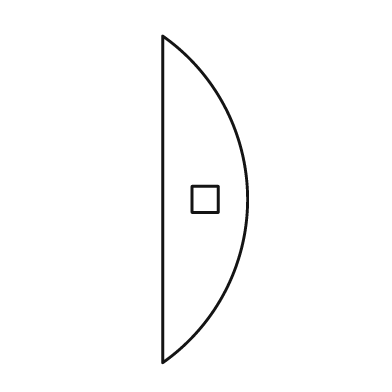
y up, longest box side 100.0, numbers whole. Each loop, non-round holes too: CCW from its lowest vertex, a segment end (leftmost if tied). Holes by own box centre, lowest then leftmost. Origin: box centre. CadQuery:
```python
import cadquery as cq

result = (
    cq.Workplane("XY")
    .moveTo(-13.0, -50.0)
    .threePointArc((13.0, 0.0), (-13.0, 50.0))
    .close()
    .moveTo(-4.0, -4.0)
    .lineTo(4.0, -4.0)
    .lineTo(4.0, 4.0)
    .lineTo(-4.0, 4.0)
    .close()
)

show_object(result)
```